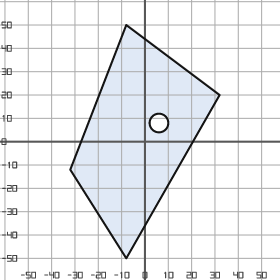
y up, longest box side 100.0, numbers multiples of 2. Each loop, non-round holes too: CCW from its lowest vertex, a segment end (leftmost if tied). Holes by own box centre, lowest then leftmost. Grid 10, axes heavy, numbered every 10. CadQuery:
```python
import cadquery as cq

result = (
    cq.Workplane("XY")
    .moveTo(-8.0, -50.0)
    .lineTo(32.0, 20.0)
    .lineTo(-8.0, 50.0)
    .lineTo(-32.0, -12.0)
    .close()
    .moveTo(6.0, 8.0)
    .circle(4.0)
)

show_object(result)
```